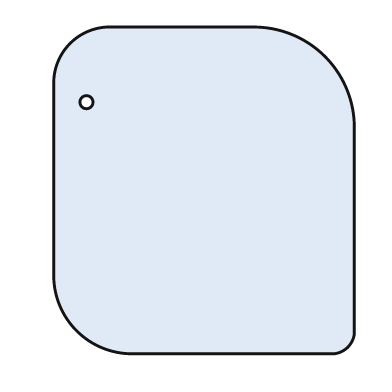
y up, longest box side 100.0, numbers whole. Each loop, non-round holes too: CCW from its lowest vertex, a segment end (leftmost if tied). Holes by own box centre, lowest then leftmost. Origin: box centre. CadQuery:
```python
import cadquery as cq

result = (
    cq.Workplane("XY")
    .moveTo(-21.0, -50.0)
    .lineTo(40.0, -50.0)
    .threePointArc((44.0, -48.0), (46.0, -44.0))
    .lineTo(46.0, 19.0)
    .threePointArc((37.0, 41.0), (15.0, 50.0))
    .lineTo(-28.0, 50.0)
    .threePointArc((-41.0, 45.0), (-46.0, 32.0))
    .lineTo(-46.0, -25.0)
    .threePointArc((-39.0, -43.0), (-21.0, -50.0))
    .close()
    .moveTo(-36.0, 27.0)
    .circle(2.0)
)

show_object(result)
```